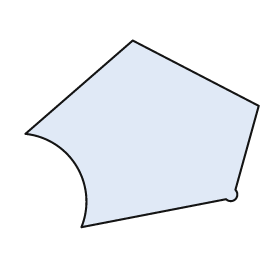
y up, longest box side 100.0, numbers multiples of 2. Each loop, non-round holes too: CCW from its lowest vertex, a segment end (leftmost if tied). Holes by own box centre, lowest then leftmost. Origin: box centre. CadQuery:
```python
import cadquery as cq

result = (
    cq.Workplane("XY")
    .moveTo(-26.0, -40.0)
    .lineTo(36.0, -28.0)
    .threePointArc((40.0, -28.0), (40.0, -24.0))
    .lineTo(50.0, 12.0)
    .lineTo(-4.0, 40.0)
    .lineTo(-50.0, 0.0)
    .threePointArc((-28.0, -14.0), (-26.0, -40.0))
    .close()
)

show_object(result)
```